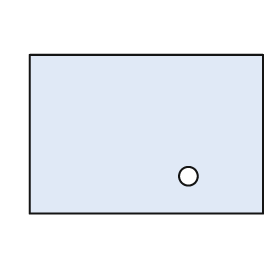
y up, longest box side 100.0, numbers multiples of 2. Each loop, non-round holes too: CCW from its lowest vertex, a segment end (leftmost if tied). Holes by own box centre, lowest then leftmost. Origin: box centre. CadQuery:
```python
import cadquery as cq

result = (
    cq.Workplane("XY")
    .moveTo(-50.0, -34.0)
    .lineTo(50.0, -34.0)
    .lineTo(50.0, 34.0)
    .lineTo(-50.0, 34.0)
    .close()
    .moveTo(18.0, -18.0)
    .circle(4.0)
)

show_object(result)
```